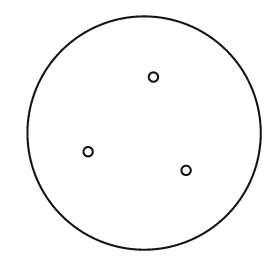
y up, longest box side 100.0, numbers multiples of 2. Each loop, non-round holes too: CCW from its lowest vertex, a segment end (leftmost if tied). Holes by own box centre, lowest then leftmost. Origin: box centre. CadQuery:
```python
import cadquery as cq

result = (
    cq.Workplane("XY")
    .moveTo(0.0, 0.0)
    .circle(50.0)
    .moveTo(18.0, -16.0)
    .circle(2.0)
    .moveTo(-24.0, -8.0)
    .circle(2.0)
    .moveTo(4.0, 24.0)
    .circle(2.0)
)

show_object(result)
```